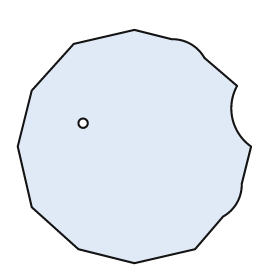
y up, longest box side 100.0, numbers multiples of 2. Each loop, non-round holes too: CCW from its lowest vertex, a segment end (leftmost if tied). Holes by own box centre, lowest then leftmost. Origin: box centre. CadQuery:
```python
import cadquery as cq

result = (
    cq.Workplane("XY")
    .moveTo(0.0, -50.0)
    .lineTo(26.0, -44.0)
    .lineTo(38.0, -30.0)
    .threePointArc((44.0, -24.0), (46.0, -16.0))
    .lineTo(50.0, 0.0)
    .threePointArc((42.0, 12.0), (44.0, 26.0))
    .lineTo(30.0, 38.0)
    .threePointArc((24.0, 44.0), (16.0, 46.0))
    .lineTo(0.0, 50.0)
    .lineTo(-26.0, 44.0)
    .lineTo(-44.0, 24.0)
    .lineTo(-50.0, 0.0)
    .lineTo(-44.0, -26.0)
    .lineTo(-24.0, -44.0)
    .close()
    .moveTo(-22.0, 10.0)
    .circle(2.0)
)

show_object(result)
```